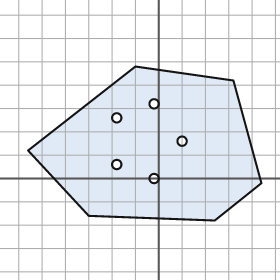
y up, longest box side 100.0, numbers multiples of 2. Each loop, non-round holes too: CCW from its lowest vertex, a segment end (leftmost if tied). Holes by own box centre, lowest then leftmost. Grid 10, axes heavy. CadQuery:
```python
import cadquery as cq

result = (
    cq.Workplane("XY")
    .moveTo(24.0, -18.0)
    .lineTo(44.0, -2.0)
    .lineTo(32.0, 42.0)
    .lineTo(-10.0, 48.0)
    .lineTo(-56.0, 12.0)
    .lineTo(-30.0, -16.0)
    .close()
    .moveTo(-2.0, 0.0)
    .circle(2.0)
    .moveTo(-18.0, 6.0)
    .circle(2.0)
    .moveTo(10.0, 16.0)
    .circle(2.0)
    .moveTo(-18.0, 26.0)
    .circle(2.0)
    .moveTo(-2.0, 32.0)
    .circle(2.0)
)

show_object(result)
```